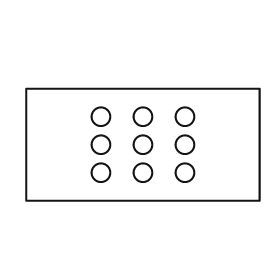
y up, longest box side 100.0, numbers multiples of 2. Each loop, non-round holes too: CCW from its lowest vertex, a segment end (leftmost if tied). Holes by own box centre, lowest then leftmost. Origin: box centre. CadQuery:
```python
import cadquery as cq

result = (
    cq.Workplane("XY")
    .moveTo(-50.0, -24.0)
    .lineTo(50.0, -24.0)
    .lineTo(50.0, 24.0)
    .lineTo(-50.0, 24.0)
    .close()
    .moveTo(-18.0, -12.0)
    .circle(4.0)
    .moveTo(0.0, -12.0)
    .circle(4.0)
    .moveTo(18.0, -12.0)
    .circle(4.0)
    .moveTo(-18.0, 0.0)
    .circle(4.0)
    .moveTo(0.0, 0.0)
    .circle(4.0)
    .moveTo(18.0, 0.0)
    .circle(4.0)
    .moveTo(-18.0, 12.0)
    .circle(4.0)
    .moveTo(0.0, 12.0)
    .circle(4.0)
    .moveTo(18.0, 12.0)
    .circle(4.0)
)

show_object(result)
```